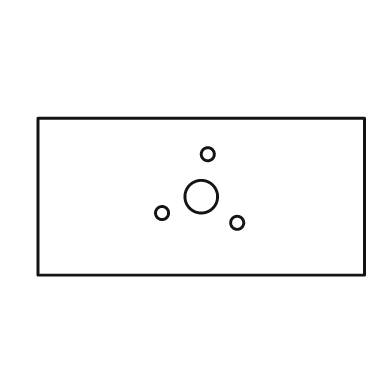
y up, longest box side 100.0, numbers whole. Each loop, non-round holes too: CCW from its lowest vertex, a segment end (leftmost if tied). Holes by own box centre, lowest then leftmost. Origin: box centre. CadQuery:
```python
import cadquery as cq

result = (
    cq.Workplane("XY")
    .moveTo(-50.0, -24.0)
    .lineTo(50.0, -24.0)
    .lineTo(50.0, 24.0)
    .lineTo(-50.0, 24.0)
    .close()
    .moveTo(11.0, -8.0)
    .circle(2.0)
    .moveTo(-12.0, -5.0)
    .circle(2.0)
    .moveTo(0.0, 0.0)
    .circle(5.0)
    .moveTo(2.0, 13.0)
    .circle(2.0)
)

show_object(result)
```